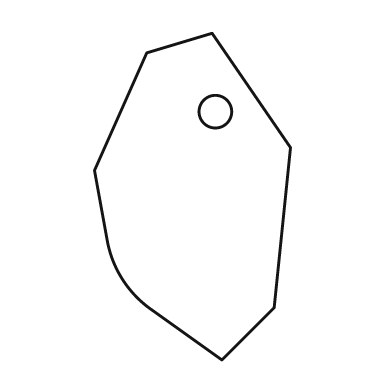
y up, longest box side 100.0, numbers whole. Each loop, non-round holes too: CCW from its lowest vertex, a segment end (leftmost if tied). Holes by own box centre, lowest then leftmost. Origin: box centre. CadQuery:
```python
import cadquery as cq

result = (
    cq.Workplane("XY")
    .moveTo(9.0, -50.0)
    .lineTo(25.0, -34.0)
    .lineTo(30.0, 15.0)
    .lineTo(6.0, 50.0)
    .lineTo(-14.0, 44.0)
    .lineTo(-30.0, 8.0)
    .lineTo(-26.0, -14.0)
    .threePointArc((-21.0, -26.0), (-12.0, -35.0))
    .close()
    .moveTo(7.0, 26.0)
    .circle(5.0)
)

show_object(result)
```